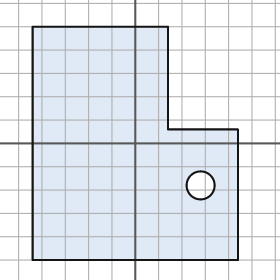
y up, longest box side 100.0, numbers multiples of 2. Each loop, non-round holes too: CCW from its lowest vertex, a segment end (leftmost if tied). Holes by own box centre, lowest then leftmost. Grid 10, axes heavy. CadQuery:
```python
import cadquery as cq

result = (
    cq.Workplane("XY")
    .moveTo(-44.0, -50.0)
    .lineTo(44.0, -50.0)
    .lineTo(44.0, 6.0)
    .lineTo(14.0, 6.0)
    .lineTo(14.0, 50.0)
    .lineTo(-44.0, 50.0)
    .close()
    .moveTo(28.0, -18.0)
    .circle(6.0)
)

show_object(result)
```